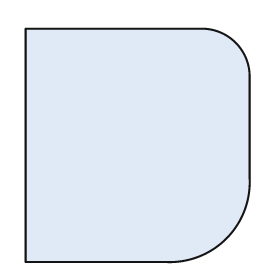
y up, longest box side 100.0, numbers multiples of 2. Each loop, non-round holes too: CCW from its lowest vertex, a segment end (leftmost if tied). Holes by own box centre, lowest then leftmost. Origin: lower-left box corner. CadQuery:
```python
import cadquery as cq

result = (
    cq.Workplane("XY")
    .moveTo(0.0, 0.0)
    .lineTo(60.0, 0.0)
    .threePointArc((86.0, 10.0), (96.0, 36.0))
    .lineTo(96.0, 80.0)
    .threePointArc((90.0, 94.0), (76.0, 100.0))
    .lineTo(0.0, 100.0)
    .close()
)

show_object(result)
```